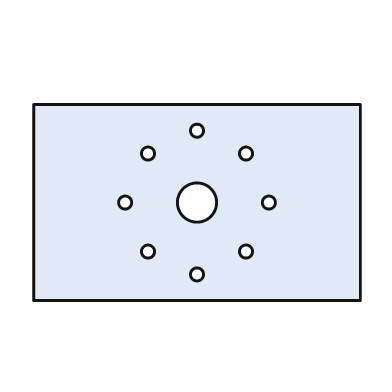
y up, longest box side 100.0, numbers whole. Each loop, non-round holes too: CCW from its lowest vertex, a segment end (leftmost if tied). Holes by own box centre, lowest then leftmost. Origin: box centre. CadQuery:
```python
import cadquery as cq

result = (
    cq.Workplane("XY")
    .moveTo(-50.0, -30.0)
    .lineTo(50.0, -30.0)
    .lineTo(50.0, 30.0)
    .lineTo(-50.0, 30.0)
    .close()
    .moveTo(0.0, -22.0)
    .circle(2.0)
    .moveTo(-15.0, -15.0)
    .circle(2.0)
    .moveTo(15.0, -15.0)
    .circle(2.0)
    .moveTo(-22.0, 0.0)
    .circle(2.0)
    .moveTo(0.0, 0.0)
    .circle(6.0)
    .moveTo(22.0, 0.0)
    .circle(2.0)
    .moveTo(-15.0, 15.0)
    .circle(2.0)
    .moveTo(15.0, 15.0)
    .circle(2.0)
    .moveTo(0.0, 22.0)
    .circle(2.0)
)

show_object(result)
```